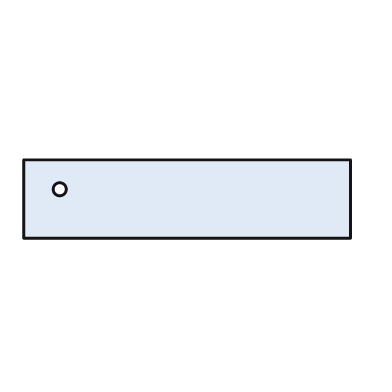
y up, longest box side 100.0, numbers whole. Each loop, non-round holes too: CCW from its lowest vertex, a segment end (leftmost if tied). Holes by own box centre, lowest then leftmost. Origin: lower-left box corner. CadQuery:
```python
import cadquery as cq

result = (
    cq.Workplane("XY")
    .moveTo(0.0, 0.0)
    .lineTo(100.0, 0.0)
    .lineTo(100.0, 24.0)
    .lineTo(0.0, 24.0)
    .close()
    .moveTo(11.0, 15.0)
    .circle(2.0)
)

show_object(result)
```